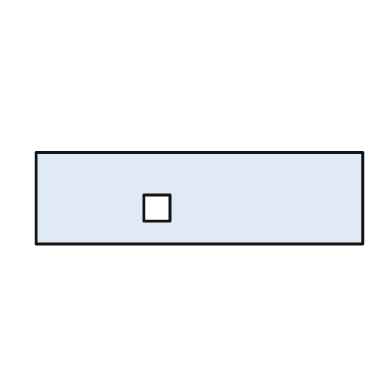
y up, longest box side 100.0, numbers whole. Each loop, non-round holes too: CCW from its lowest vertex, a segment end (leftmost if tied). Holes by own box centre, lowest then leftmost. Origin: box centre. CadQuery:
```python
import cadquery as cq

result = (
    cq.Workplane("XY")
    .moveTo(-50.0, -14.0)
    .lineTo(50.0, -14.0)
    .lineTo(50.0, 14.0)
    .lineTo(-50.0, 14.0)
    .close()
    .moveTo(-17.0, -7.0)
    .lineTo(-9.0, -7.0)
    .lineTo(-9.0, 1.0)
    .lineTo(-17.0, 1.0)
    .close()
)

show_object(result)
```